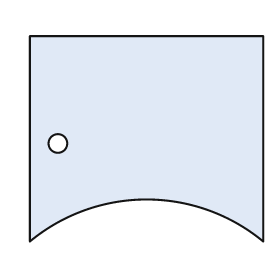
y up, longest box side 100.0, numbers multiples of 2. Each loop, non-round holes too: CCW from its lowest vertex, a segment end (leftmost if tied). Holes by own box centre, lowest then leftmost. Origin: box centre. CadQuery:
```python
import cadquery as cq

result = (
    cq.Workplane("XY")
    .moveTo(-50.0, -44.0)
    .threePointArc((0.0, -26.0), (50.0, -44.0))
    .lineTo(50.0, 44.0)
    .lineTo(-50.0, 44.0)
    .close()
    .moveTo(-38.0, -2.0)
    .circle(4.0)
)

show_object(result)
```